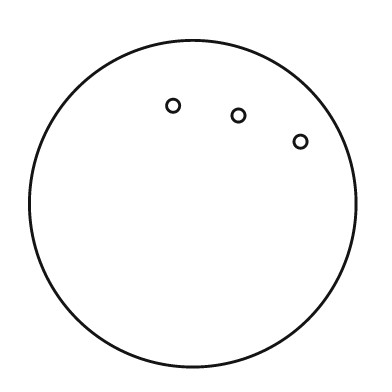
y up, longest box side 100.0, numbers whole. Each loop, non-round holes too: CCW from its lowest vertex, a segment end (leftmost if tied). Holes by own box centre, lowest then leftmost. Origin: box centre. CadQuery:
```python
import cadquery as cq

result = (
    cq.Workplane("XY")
    .moveTo(0.0, 0.0)
    .circle(50.0)
    .moveTo(33.0, 19.0)
    .circle(2.0)
    .moveTo(14.0, 27.0)
    .circle(2.0)
    .moveTo(-6.0, 30.0)
    .circle(2.0)
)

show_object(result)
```